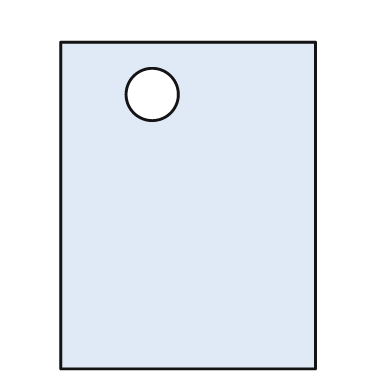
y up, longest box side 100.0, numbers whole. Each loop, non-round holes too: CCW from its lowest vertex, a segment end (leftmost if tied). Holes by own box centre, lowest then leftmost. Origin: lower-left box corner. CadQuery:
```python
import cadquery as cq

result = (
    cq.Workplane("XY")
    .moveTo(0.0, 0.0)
    .lineTo(78.0, 0.0)
    .lineTo(78.0, 100.0)
    .lineTo(0.0, 100.0)
    .close()
    .moveTo(28.0, 84.0)
    .circle(8.0)
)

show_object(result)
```